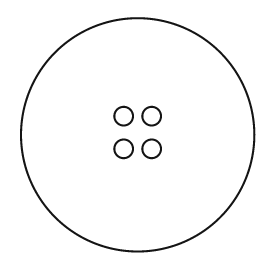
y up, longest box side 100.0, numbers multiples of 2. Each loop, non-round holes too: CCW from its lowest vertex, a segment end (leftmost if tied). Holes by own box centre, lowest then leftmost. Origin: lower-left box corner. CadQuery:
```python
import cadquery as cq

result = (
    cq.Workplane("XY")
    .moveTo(50.0, 50.0)
    .circle(50.0)
    .moveTo(44.0, 44.0)
    .circle(4.0)
    .moveTo(56.0, 44.0)
    .circle(4.0)
    .moveTo(44.0, 58.0)
    .circle(4.0)
    .moveTo(56.0, 58.0)
    .circle(4.0)
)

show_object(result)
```